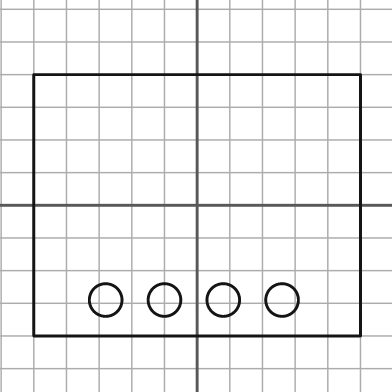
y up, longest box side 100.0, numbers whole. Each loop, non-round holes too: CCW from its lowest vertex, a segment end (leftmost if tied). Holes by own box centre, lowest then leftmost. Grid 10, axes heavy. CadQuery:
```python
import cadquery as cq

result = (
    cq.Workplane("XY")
    .moveTo(-50.0, -40.0)
    .lineTo(50.0, -40.0)
    .lineTo(50.0, 40.0)
    .lineTo(-50.0, 40.0)
    .close()
    .moveTo(-28.0, -29.0)
    .circle(5.0)
    .moveTo(-10.0, -29.0)
    .circle(5.0)
    .moveTo(8.0, -29.0)
    .circle(5.0)
    .moveTo(26.0, -29.0)
    .circle(5.0)
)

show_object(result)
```